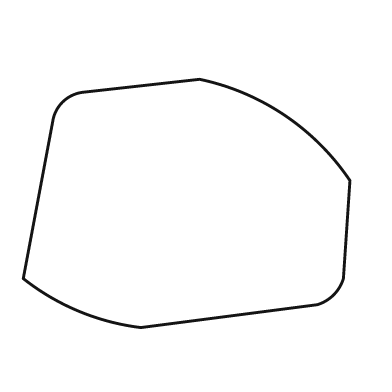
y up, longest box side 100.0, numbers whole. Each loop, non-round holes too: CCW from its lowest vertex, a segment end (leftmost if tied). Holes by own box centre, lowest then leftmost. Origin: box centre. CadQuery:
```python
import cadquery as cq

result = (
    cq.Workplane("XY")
    .moveTo(-14.0, -38.0)
    .lineTo(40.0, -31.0)
    .threePointArc((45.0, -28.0), (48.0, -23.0))
    .lineTo(50.0, 7.0)
    .threePointArc((30.0, 27.0), (4.0, 38.0))
    .lineTo(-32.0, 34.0)
    .threePointArc((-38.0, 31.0), (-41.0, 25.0))
    .lineTo(-50.0, -23.0)
    .threePointArc((-33.0, -33.0), (-14.0, -38.0))
    .close()
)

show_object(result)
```